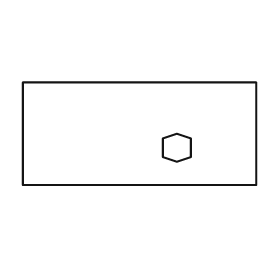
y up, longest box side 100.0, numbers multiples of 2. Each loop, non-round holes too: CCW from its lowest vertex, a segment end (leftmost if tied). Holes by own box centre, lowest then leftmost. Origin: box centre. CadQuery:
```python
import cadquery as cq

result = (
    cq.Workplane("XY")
    .moveTo(-50.0, -22.0)
    .lineTo(50.0, -22.0)
    .lineTo(50.0, 22.0)
    .lineTo(-50.0, 22.0)
    .close()
    .moveTo(16.0, -12.0)
    .lineTo(22.0, -10.0)
    .lineTo(22.0, -2.0)
    .lineTo(16.0, 0.0)
    .lineTo(10.0, -2.0)
    .lineTo(10.0, -10.0)
    .close()
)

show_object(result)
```